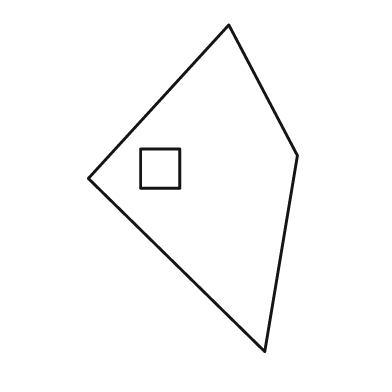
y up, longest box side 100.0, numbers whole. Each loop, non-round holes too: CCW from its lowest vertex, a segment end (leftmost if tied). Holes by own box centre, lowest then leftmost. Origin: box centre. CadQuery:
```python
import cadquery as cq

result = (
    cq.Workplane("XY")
    .moveTo(22.0, -50.0)
    .lineTo(32.0, 10.0)
    .lineTo(11.0, 50.0)
    .lineTo(-32.0, 3.0)
    .close()
    .moveTo(-16.0, 0.0)
    .lineTo(-4.0, 0.0)
    .lineTo(-4.0, 12.0)
    .lineTo(-16.0, 12.0)
    .close()
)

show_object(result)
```